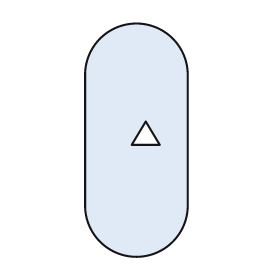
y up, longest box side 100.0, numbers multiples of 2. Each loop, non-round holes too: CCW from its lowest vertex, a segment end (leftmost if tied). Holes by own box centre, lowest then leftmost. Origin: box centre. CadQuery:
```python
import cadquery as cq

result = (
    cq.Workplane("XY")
    .moveTo(-22.0, -28.0)
    .threePointArc((0.0, -50.0), (22.0, -28.0))
    .lineTo(22.0, 28.0)
    .threePointArc((0.0, 50.0), (-22.0, 28.0))
    .close()
    .moveTo(-2.0, -2.0)
    .lineTo(10.0, -2.0)
    .lineTo(4.0, 8.0)
    .close()
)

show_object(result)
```